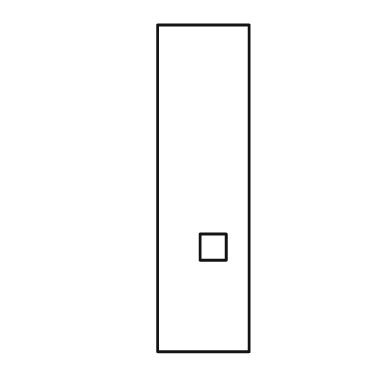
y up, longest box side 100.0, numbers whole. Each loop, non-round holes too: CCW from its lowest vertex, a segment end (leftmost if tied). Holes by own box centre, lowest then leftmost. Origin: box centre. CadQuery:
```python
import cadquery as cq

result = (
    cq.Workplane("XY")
    .moveTo(-14.0, -50.0)
    .lineTo(14.0, -50.0)
    .lineTo(14.0, 50.0)
    .lineTo(-14.0, 50.0)
    .close()
    .moveTo(-1.0, -22.0)
    .lineTo(7.0, -22.0)
    .lineTo(7.0, -14.0)
    .lineTo(-1.0, -14.0)
    .close()
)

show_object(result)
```